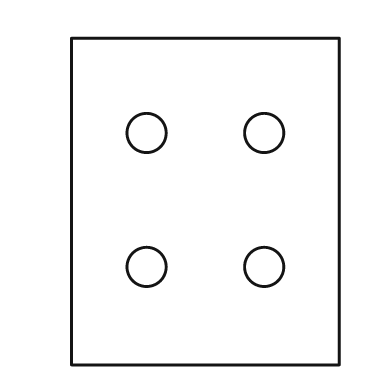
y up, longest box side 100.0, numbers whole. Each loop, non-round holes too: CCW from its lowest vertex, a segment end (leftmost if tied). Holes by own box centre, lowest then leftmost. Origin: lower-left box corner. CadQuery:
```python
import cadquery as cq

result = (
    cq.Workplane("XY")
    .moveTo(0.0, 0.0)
    .lineTo(82.0, 0.0)
    .lineTo(82.0, 100.0)
    .lineTo(0.0, 100.0)
    .close()
    .moveTo(23.0, 30.0)
    .circle(6.0)
    .moveTo(59.0, 30.0)
    .circle(6.0)
    .moveTo(23.0, 71.0)
    .circle(6.0)
    .moveTo(59.0, 71.0)
    .circle(6.0)
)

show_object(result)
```